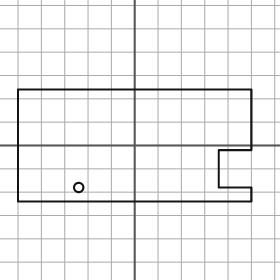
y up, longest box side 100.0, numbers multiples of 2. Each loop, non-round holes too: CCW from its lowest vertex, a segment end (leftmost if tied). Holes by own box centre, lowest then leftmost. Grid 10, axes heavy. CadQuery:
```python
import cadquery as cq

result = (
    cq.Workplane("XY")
    .moveTo(-50.0, -24.0)
    .lineTo(50.0, -24.0)
    .lineTo(50.0, -18.0)
    .lineTo(36.0, -18.0)
    .lineTo(36.0, -2.0)
    .lineTo(50.0, -2.0)
    .lineTo(50.0, 24.0)
    .lineTo(-50.0, 24.0)
    .close()
    .moveTo(-24.0, -18.0)
    .circle(2.0)
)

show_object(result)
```